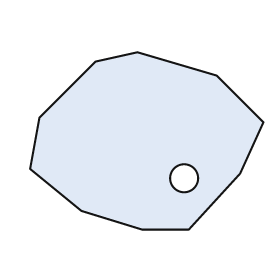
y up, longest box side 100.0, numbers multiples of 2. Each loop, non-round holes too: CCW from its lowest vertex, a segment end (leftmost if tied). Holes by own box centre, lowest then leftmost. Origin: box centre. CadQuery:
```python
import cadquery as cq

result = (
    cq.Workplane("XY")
    .moveTo(-2.0, -38.0)
    .lineTo(18.0, -38.0)
    .lineTo(40.0, -14.0)
    .lineTo(50.0, 8.0)
    .lineTo(30.0, 28.0)
    .lineTo(-4.0, 38.0)
    .lineTo(-22.0, 34.0)
    .lineTo(-46.0, 10.0)
    .lineTo(-50.0, -12.0)
    .lineTo(-28.0, -30.0)
    .close()
    .moveTo(16.0, -16.0)
    .circle(6.0)
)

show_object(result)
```